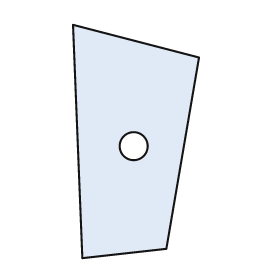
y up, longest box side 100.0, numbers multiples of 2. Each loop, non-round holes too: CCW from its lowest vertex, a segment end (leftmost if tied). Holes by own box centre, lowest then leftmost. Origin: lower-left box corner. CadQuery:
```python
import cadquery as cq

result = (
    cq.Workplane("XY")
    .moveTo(4.0, 0.0)
    .lineTo(40.0, 4.0)
    .lineTo(54.0, 86.0)
    .lineTo(0.0, 100.0)
    .close()
    .moveTo(26.0, 48.0)
    .circle(6.0)
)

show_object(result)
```